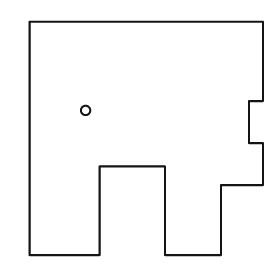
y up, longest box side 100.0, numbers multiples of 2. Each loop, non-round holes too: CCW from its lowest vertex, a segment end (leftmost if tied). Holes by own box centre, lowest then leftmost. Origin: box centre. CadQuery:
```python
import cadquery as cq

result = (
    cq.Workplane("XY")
    .moveTo(-50.0, -50.0)
    .lineTo(-20.0, -50.0)
    .lineTo(-20.0, -12.0)
    .lineTo(8.0, -12.0)
    .lineTo(8.0, -50.0)
    .lineTo(32.0, -50.0)
    .lineTo(32.0, -20.0)
    .lineTo(50.0, -20.0)
    .lineTo(50.0, -2.0)
    .lineTo(44.0, -2.0)
    .lineTo(44.0, 16.0)
    .lineTo(50.0, 16.0)
    .lineTo(50.0, 50.0)
    .lineTo(-50.0, 50.0)
    .close()
    .moveTo(-26.0, 12.0)
    .circle(2.0)
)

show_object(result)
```